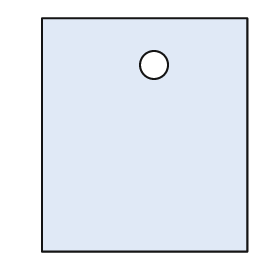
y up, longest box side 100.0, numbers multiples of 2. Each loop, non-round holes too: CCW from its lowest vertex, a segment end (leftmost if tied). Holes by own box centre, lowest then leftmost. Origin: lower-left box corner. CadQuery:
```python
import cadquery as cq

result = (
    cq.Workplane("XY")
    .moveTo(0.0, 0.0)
    .lineTo(88.0, 0.0)
    .lineTo(88.0, 100.0)
    .lineTo(0.0, 100.0)
    .close()
    .moveTo(48.0, 80.0)
    .circle(6.0)
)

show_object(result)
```